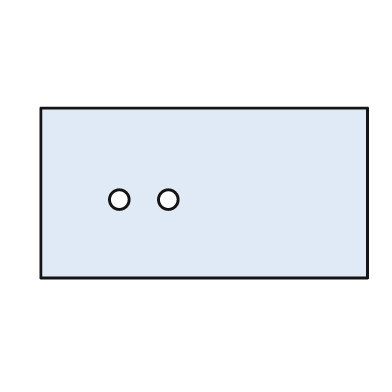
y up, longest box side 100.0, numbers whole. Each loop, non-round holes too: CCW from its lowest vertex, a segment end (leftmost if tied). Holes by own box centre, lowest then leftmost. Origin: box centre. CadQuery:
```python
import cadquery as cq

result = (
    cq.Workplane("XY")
    .moveTo(-50.0, -26.0)
    .lineTo(50.0, -26.0)
    .lineTo(50.0, 26.0)
    .lineTo(-50.0, 26.0)
    .close()
    .moveTo(-26.0, -2.0)
    .circle(3.0)
    .moveTo(-11.0, -2.0)
    .circle(3.0)
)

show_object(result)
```